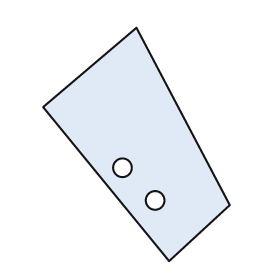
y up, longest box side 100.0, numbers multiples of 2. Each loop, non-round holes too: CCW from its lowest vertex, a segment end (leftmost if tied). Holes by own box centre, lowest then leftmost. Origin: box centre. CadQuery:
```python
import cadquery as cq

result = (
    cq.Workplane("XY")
    .moveTo(14.0, -50.0)
    .lineTo(40.0, -26.0)
    .lineTo(0.0, 50.0)
    .lineTo(-40.0, 16.0)
    .close()
    .moveTo(8.0, -24.0)
    .circle(4.0)
    .moveTo(-6.0, -10.0)
    .circle(4.0)
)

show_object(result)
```